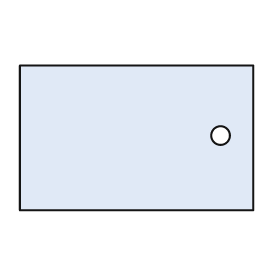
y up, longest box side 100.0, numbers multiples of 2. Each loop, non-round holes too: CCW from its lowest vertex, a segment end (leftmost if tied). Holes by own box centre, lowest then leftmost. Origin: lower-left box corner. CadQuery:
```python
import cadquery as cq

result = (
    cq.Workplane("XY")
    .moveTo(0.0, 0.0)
    .lineTo(100.0, 0.0)
    .lineTo(100.0, 62.0)
    .lineTo(0.0, 62.0)
    .close()
    .moveTo(86.0, 32.0)
    .circle(4.0)
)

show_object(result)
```